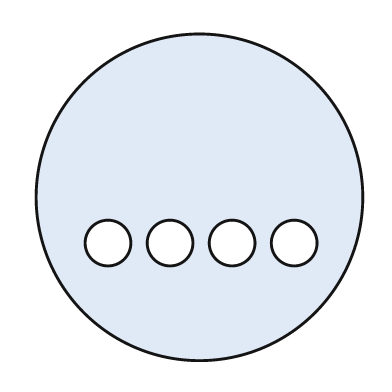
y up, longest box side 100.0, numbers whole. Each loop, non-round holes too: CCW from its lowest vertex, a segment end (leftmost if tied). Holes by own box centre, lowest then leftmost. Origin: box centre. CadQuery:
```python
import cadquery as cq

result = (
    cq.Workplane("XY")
    .moveTo(0.0, 0.0)
    .circle(50.0)
    .moveTo(-28.0, -14.0)
    .circle(7.0)
    .moveTo(-9.0, -14.0)
    .circle(7.0)
    .moveTo(10.0, -14.0)
    .circle(7.0)
    .moveTo(29.0, -14.0)
    .circle(7.0)
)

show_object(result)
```